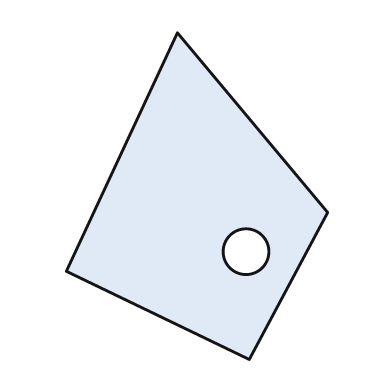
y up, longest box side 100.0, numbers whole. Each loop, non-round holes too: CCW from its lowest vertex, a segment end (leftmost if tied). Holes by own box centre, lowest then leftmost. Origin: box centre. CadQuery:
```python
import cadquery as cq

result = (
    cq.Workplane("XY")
    .moveTo(16.0, -50.0)
    .lineTo(40.0, -5.0)
    .lineTo(-6.0, 50.0)
    .lineTo(-40.0, -23.0)
    .close()
    .moveTo(15.0, -17.0)
    .circle(7.0)
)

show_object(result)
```